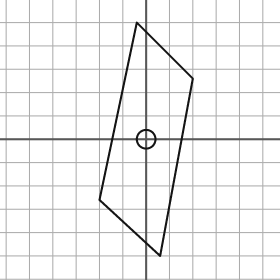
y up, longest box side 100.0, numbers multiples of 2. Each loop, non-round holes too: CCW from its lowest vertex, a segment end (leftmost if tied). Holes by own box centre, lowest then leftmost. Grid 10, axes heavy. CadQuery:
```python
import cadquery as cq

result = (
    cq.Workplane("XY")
    .moveTo(6.0, -50.0)
    .lineTo(20.0, 26.0)
    .lineTo(-4.0, 50.0)
    .lineTo(-20.0, -26.0)
    .close()
    .moveTo(0.0, 0.0)
    .circle(4.0)
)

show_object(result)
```